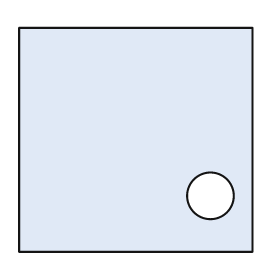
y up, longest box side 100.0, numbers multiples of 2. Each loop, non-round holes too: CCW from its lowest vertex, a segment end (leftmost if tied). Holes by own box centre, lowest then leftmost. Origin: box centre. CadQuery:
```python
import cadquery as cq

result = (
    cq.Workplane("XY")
    .moveTo(-50.0, -48.0)
    .lineTo(50.0, -48.0)
    .lineTo(50.0, 48.0)
    .lineTo(-50.0, 48.0)
    .close()
    .moveTo(32.0, -24.0)
    .circle(10.0)
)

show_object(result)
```